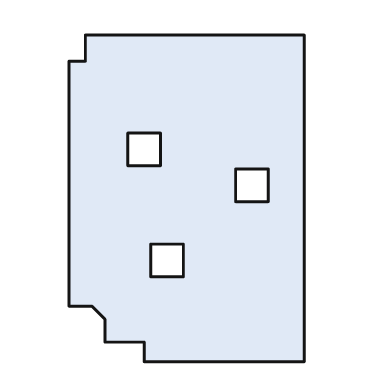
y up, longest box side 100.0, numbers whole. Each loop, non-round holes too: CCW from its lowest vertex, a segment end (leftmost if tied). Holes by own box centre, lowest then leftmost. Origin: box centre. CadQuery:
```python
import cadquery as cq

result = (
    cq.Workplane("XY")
    .moveTo(-13.0, -50.0)
    .lineTo(36.0, -50.0)
    .lineTo(36.0, 50.0)
    .lineTo(-31.0, 50.0)
    .lineTo(-31.0, 42.0)
    .lineTo(-36.0, 42.0)
    .lineTo(-36.0, -33.0)
    .lineTo(-29.0, -33.0)
    .lineTo(-25.0, -37.0)
    .lineTo(-25.0, -44.0)
    .lineTo(-13.0, -44.0)
    .close()
    .moveTo(-11.0, -24.0)
    .lineTo(-1.0, -24.0)
    .lineTo(-1.0, -14.0)
    .lineTo(-11.0, -14.0)
    .close()
    .moveTo(15.0, -1.0)
    .lineTo(25.0, -1.0)
    .lineTo(25.0, 9.0)
    .lineTo(15.0, 9.0)
    .close()
    .moveTo(-18.0, 10.0)
    .lineTo(-8.0, 10.0)
    .lineTo(-8.0, 20.0)
    .lineTo(-18.0, 20.0)
    .close()
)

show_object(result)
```